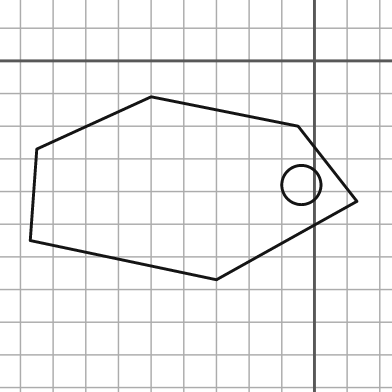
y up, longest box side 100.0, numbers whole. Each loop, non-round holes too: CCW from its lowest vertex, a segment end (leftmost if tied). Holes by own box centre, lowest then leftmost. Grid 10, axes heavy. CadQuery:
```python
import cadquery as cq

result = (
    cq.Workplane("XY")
    .moveTo(-30.0, -67.0)
    .lineTo(13.0, -43.0)
    .lineTo(-5.0, -20.0)
    .lineTo(-50.0, -11.0)
    .lineTo(-85.0, -27.0)
    .lineTo(-87.0, -55.0)
    .close()
    .moveTo(-4.0, -38.0)
    .circle(6.0)
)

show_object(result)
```